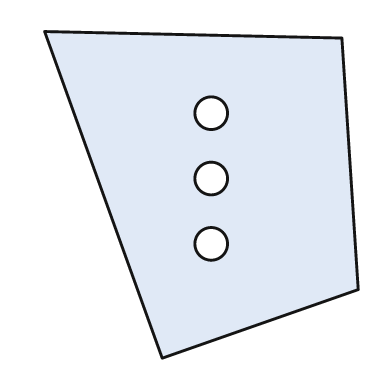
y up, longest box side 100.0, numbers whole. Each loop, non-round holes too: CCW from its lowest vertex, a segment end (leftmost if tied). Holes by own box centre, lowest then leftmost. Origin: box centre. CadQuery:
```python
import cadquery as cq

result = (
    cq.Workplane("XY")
    .moveTo(-12.0, -50.0)
    .lineTo(48.0, -29.0)
    .lineTo(43.0, 48.0)
    .lineTo(-48.0, 50.0)
    .close()
    .moveTo(3.0, -15.0)
    .circle(5.0)
    .moveTo(3.0, 5.0)
    .circle(5.0)
    .moveTo(3.0, 25.0)
    .circle(5.0)
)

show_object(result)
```